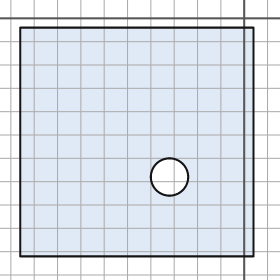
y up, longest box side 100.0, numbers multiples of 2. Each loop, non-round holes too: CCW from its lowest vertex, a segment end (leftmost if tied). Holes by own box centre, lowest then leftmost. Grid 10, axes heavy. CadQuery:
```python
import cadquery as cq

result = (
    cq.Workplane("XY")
    .moveTo(-96.0, -102.0)
    .lineTo(4.0, -102.0)
    .lineTo(4.0, -4.0)
    .lineTo(-96.0, -4.0)
    .close()
    .moveTo(-32.0, -68.0)
    .circle(8.0)
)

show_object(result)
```